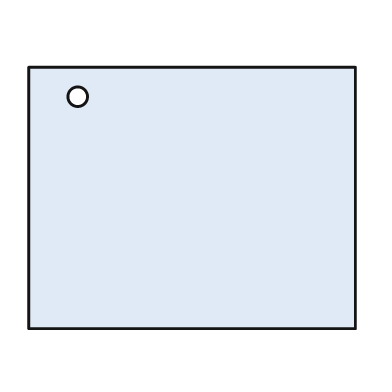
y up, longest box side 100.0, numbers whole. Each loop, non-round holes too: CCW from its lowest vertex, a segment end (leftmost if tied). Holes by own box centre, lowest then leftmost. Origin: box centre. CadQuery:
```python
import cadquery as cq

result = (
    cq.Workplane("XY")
    .moveTo(-50.0, -40.0)
    .lineTo(50.0, -40.0)
    .lineTo(50.0, 40.0)
    .lineTo(-50.0, 40.0)
    .close()
    .moveTo(-35.0, 31.0)
    .circle(3.0)
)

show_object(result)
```